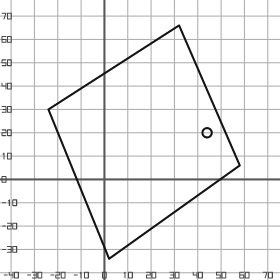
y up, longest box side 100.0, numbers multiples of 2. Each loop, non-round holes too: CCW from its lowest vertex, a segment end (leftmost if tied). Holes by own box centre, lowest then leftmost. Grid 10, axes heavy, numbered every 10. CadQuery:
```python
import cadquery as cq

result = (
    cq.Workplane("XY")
    .moveTo(2.0, -34.0)
    .lineTo(58.0, 6.0)
    .lineTo(32.0, 66.0)
    .lineTo(-24.0, 30.0)
    .close()
    .moveTo(44.0, 20.0)
    .circle(2.0)
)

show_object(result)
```